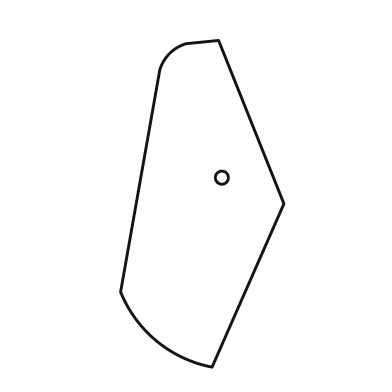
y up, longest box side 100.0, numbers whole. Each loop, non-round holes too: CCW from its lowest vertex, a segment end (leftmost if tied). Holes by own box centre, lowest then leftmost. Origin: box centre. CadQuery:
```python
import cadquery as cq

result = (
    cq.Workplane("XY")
    .moveTo(3.0, -50.0)
    .lineTo(25.0, 0.0)
    .lineTo(5.0, 50.0)
    .lineTo(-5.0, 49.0)
    .threePointArc((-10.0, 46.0), (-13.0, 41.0))
    .lineTo(-25.0, -27.0)
    .threePointArc((-14.0, -42.0), (3.0, -50.0))
    .close()
    .moveTo(6.0, 8.0)
    .circle(2.0)
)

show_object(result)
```